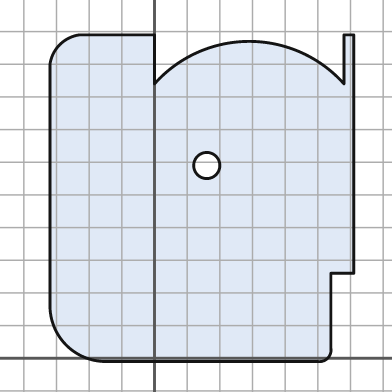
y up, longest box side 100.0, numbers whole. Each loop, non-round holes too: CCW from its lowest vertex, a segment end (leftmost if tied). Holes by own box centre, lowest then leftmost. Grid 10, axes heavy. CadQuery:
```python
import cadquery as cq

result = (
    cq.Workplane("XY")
    .moveTo(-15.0, -1.0)
    .lineTo(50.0, -1.0)
    .threePointArc((53.0, 0.0), (54.0, 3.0))
    .lineTo(54.0, 26.0)
    .lineTo(61.0, 26.0)
    .lineTo(61.0, 99.0)
    .lineTo(58.0, 99.0)
    .lineTo(58.0, 84.0)
    .threePointArc((29.0, 97.0), (0.0, 84.0))
    .lineTo(0.0, 99.0)
    .lineTo(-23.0, 99.0)
    .threePointArc((-29.0, 96.0), (-32.0, 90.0))
    .lineTo(-32.0, 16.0)
    .threePointArc((-27.0, 4.0), (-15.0, -1.0))
    .close()
    .moveTo(16.0, 59.0)
    .circle(4.0)
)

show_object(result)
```